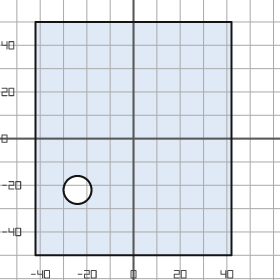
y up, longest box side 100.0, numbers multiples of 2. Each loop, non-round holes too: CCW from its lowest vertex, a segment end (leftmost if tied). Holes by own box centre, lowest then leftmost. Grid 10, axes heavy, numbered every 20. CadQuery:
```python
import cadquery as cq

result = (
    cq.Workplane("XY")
    .moveTo(-42.0, -50.0)
    .lineTo(42.0, -50.0)
    .lineTo(42.0, 50.0)
    .lineTo(-42.0, 50.0)
    .close()
    .moveTo(-24.0, -22.0)
    .circle(6.0)
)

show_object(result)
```